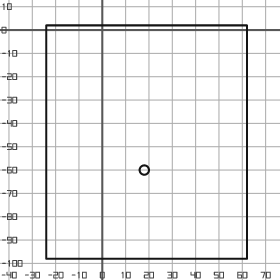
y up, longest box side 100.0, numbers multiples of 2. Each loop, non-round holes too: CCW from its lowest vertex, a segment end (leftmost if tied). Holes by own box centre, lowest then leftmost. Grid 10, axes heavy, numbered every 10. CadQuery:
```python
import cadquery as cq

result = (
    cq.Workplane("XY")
    .moveTo(-24.0, -98.0)
    .lineTo(62.0, -98.0)
    .lineTo(62.0, 2.0)
    .lineTo(-24.0, 2.0)
    .close()
    .moveTo(18.0, -60.0)
    .circle(2.0)
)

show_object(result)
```